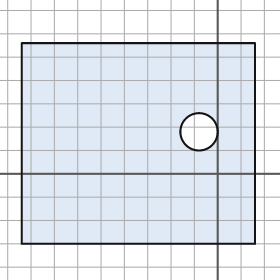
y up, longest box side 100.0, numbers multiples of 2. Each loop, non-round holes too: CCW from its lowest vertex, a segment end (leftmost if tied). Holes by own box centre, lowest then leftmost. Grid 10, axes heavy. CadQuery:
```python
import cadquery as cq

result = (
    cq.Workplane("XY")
    .moveTo(-84.0, -30.0)
    .lineTo(16.0, -30.0)
    .lineTo(16.0, 56.0)
    .lineTo(-84.0, 56.0)
    .close()
    .moveTo(-8.0, 18.0)
    .circle(8.0)
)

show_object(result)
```